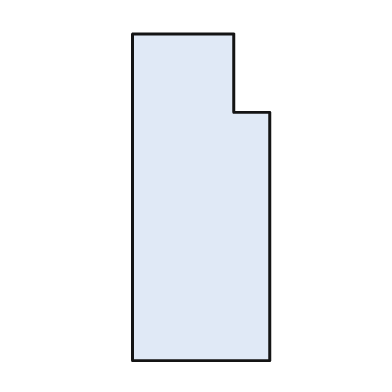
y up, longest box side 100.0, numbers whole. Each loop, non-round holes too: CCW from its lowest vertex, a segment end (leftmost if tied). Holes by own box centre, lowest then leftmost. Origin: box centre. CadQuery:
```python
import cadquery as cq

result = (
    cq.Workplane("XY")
    .moveTo(-21.0, -50.0)
    .lineTo(21.0, -50.0)
    .lineTo(21.0, 26.0)
    .lineTo(10.0, 26.0)
    .lineTo(10.0, 50.0)
    .lineTo(-21.0, 50.0)
    .close()
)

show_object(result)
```